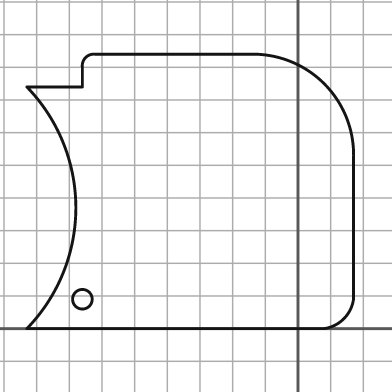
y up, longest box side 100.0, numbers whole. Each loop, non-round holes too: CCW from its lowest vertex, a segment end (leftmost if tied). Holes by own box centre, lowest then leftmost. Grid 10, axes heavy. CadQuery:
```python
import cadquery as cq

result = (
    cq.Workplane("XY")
    .moveTo(-83.0, 0.0)
    .lineTo(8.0, 0.0)
    .threePointArc((14.0, 3.0), (17.0, 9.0))
    .lineTo(17.0, 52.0)
    .threePointArc((8.0, 75.0), (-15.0, 84.0))
    .lineTo(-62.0, 84.0)
    .threePointArc((-65.0, 83.0), (-66.0, 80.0))
    .lineTo(-66.0, 74.0)
    .lineTo(-83.0, 74.0)
    .threePointArc((-68.0, 37.0), (-83.0, 0.0))
    .close()
    .moveTo(-66.0, 9.0)
    .circle(3.0)
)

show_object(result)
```